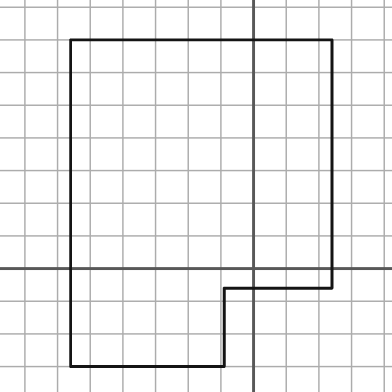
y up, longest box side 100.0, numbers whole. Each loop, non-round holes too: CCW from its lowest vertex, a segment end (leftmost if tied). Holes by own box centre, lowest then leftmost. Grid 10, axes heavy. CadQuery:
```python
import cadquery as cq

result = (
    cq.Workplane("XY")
    .moveTo(-56.0, -30.0)
    .lineTo(-9.0, -30.0)
    .lineTo(-9.0, -6.0)
    .lineTo(24.0, -6.0)
    .lineTo(24.0, 70.0)
    .lineTo(-56.0, 70.0)
    .close()
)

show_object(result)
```